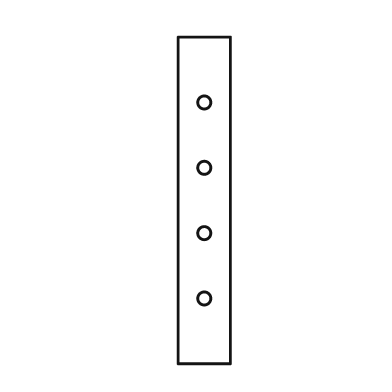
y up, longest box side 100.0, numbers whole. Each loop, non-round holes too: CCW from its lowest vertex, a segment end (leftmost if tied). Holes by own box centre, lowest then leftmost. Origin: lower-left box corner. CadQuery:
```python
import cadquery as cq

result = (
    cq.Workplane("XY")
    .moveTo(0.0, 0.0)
    .lineTo(16.0, 0.0)
    .lineTo(16.0, 100.0)
    .lineTo(0.0, 100.0)
    .close()
    .moveTo(8.0, 20.0)
    .circle(2.0)
    .moveTo(8.0, 40.0)
    .circle(2.0)
    .moveTo(8.0, 60.0)
    .circle(2.0)
    .moveTo(8.0, 80.0)
    .circle(2.0)
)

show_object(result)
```